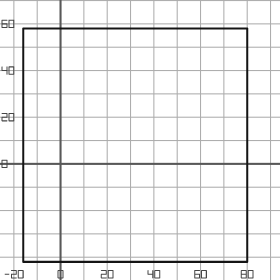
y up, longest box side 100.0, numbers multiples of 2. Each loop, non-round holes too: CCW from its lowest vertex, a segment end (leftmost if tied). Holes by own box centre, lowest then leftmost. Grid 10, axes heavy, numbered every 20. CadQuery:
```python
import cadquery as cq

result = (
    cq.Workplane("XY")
    .moveTo(-16.0, -42.0)
    .lineTo(80.0, -42.0)
    .lineTo(80.0, 58.0)
    .lineTo(-16.0, 58.0)
    .close()
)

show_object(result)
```